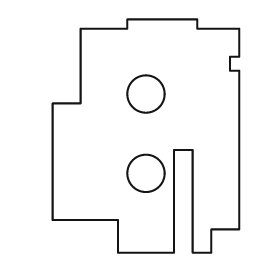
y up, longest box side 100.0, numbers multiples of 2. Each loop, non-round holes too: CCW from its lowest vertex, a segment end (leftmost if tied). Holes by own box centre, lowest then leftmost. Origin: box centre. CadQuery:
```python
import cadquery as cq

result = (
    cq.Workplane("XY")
    .moveTo(-12.0, -50.0)
    .lineTo(12.0, -50.0)
    .lineTo(12.0, -6.0)
    .lineTo(20.0, -6.0)
    .lineTo(20.0, -50.0)
    .lineTo(28.0, -50.0)
    .lineTo(28.0, -40.0)
    .lineTo(40.0, -40.0)
    .lineTo(40.0, 28.0)
    .lineTo(36.0, 28.0)
    .lineTo(36.0, 34.0)
    .lineTo(40.0, 34.0)
    .lineTo(40.0, 46.0)
    .lineTo(22.0, 46.0)
    .lineTo(22.0, 50.0)
    .lineTo(-8.0, 50.0)
    .lineTo(-8.0, 46.0)
    .lineTo(-28.0, 46.0)
    .lineTo(-28.0, 14.0)
    .lineTo(-40.0, 14.0)
    .lineTo(-40.0, -36.0)
    .lineTo(-12.0, -36.0)
    .close()
    .moveTo(0.0, -16.0)
    .circle(8.0)
    .moveTo(0.0, 18.0)
    .circle(8.0)
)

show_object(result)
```